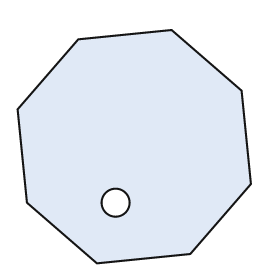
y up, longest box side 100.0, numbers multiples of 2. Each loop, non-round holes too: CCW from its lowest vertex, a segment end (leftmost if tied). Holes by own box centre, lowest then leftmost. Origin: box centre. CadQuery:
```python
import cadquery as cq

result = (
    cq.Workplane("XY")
    .moveTo(-16.0, -50.0)
    .lineTo(24.0, -46.0)
    .lineTo(50.0, -16.0)
    .lineTo(46.0, 24.0)
    .lineTo(16.0, 50.0)
    .lineTo(-24.0, 46.0)
    .lineTo(-50.0, 16.0)
    .lineTo(-46.0, -24.0)
    .close()
    .moveTo(-8.0, -24.0)
    .circle(6.0)
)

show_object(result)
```